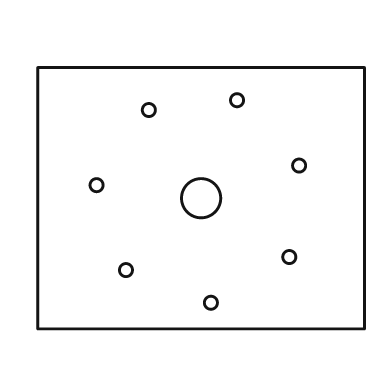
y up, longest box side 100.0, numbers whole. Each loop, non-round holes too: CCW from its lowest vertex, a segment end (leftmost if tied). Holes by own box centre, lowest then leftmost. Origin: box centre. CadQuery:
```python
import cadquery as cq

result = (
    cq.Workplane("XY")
    .moveTo(-50.0, -40.0)
    .lineTo(50.0, -40.0)
    .lineTo(50.0, 40.0)
    .lineTo(-50.0, 40.0)
    .close()
    .moveTo(3.0, -32.0)
    .circle(2.0)
    .moveTo(-23.0, -22.0)
    .circle(2.0)
    .moveTo(27.0, -18.0)
    .circle(2.0)
    .moveTo(0.0, 0.0)
    .circle(6.0)
    .moveTo(-32.0, 4.0)
    .circle(2.0)
    .moveTo(30.0, 10.0)
    .circle(2.0)
    .moveTo(-16.0, 27.0)
    .circle(2.0)
    .moveTo(11.0, 30.0)
    .circle(2.0)
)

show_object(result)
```